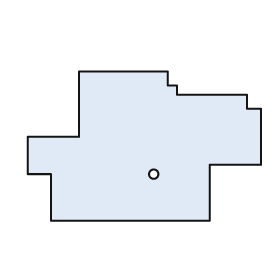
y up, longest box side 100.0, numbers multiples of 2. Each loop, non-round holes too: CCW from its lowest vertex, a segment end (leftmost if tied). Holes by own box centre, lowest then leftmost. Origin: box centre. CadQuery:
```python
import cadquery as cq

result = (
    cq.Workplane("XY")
    .moveTo(-40.0, -32.0)
    .lineTo(28.0, -32.0)
    .lineTo(28.0, -8.0)
    .lineTo(50.0, -8.0)
    .lineTo(50.0, 16.0)
    .lineTo(44.0, 16.0)
    .lineTo(44.0, 22.0)
    .lineTo(14.0, 22.0)
    .lineTo(14.0, 26.0)
    .lineTo(10.0, 26.0)
    .lineTo(10.0, 32.0)
    .lineTo(-28.0, 32.0)
    .lineTo(-28.0, 4.0)
    .lineTo(-50.0, 4.0)
    .lineTo(-50.0, -12.0)
    .lineTo(-40.0, -12.0)
    .close()
    .moveTo(4.0, -12.0)
    .circle(2.0)
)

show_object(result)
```